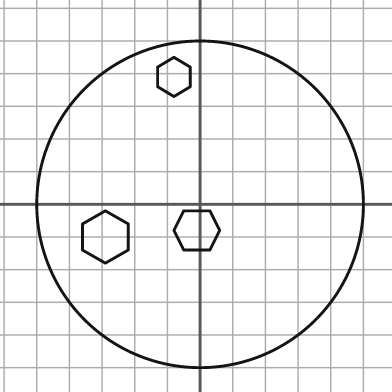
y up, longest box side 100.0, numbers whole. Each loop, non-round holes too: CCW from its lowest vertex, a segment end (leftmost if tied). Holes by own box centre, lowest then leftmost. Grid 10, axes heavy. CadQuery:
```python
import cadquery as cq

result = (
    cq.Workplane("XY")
    .moveTo(0.0, 0.0)
    .circle(50.0)
    .moveTo(-29.0, -18.0)
    .lineTo(-22.0, -14.0)
    .lineTo(-22.0, -6.0)
    .lineTo(-29.0, -2.0)
    .lineTo(-36.0, -6.0)
    .lineTo(-36.0, -14.0)
    .close()
    .moveTo(-5.0, -14.0)
    .lineTo(3.0, -14.0)
    .lineTo(6.0, -8.0)
    .lineTo(3.0, -2.0)
    .lineTo(-5.0, -2.0)
    .lineTo(-8.0, -8.0)
    .close()
    .moveTo(-8.0, 33.0)
    .lineTo(-3.0, 36.0)
    .lineTo(-3.0, 42.0)
    .lineTo(-8.0, 45.0)
    .lineTo(-13.0, 42.0)
    .lineTo(-13.0, 36.0)
    .close()
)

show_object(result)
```